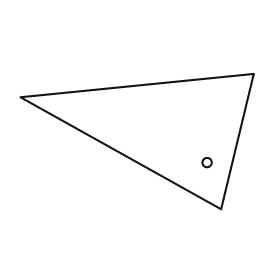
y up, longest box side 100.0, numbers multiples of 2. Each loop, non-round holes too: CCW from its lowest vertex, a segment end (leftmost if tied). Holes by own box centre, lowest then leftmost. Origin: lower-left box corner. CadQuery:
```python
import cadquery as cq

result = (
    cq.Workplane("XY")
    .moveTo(86.0, 0.0)
    .lineTo(100.0, 58.0)
    .lineTo(0.0, 48.0)
    .close()
    .moveTo(80.0, 20.0)
    .circle(2.0)
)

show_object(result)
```